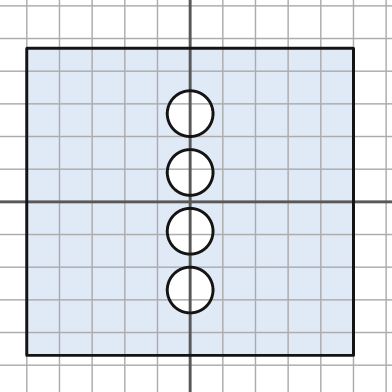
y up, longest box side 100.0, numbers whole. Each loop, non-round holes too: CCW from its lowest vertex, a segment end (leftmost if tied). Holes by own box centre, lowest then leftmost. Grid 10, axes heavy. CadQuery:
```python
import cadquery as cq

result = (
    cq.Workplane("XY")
    .moveTo(-50.0, -47.0)
    .lineTo(50.0, -47.0)
    .lineTo(50.0, 47.0)
    .lineTo(-50.0, 47.0)
    .close()
    .moveTo(0.0, -27.0)
    .circle(7.0)
    .moveTo(0.0, -9.0)
    .circle(7.0)
    .moveTo(0.0, 9.0)
    .circle(7.0)
    .moveTo(0.0, 27.0)
    .circle(7.0)
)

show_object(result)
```